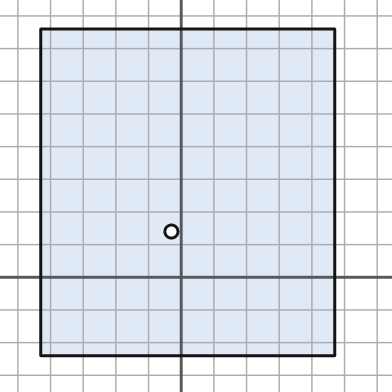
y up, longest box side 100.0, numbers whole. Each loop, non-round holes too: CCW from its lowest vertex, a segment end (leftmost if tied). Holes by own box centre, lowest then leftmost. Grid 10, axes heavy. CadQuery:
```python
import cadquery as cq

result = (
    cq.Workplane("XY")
    .moveTo(-43.0, -24.0)
    .lineTo(47.0, -24.0)
    .lineTo(47.0, 76.0)
    .lineTo(-43.0, 76.0)
    .close()
    .moveTo(-3.0, 14.0)
    .circle(2.0)
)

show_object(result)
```